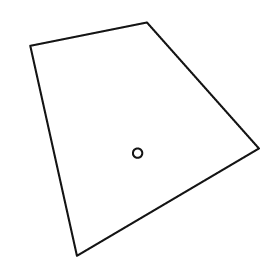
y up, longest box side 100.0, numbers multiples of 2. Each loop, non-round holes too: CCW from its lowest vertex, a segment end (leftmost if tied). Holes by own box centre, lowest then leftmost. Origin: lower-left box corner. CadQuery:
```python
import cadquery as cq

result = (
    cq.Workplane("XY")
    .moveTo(20.0, 0.0)
    .lineTo(98.0, 46.0)
    .lineTo(50.0, 100.0)
    .lineTo(0.0, 90.0)
    .close()
    .moveTo(46.0, 44.0)
    .circle(2.0)
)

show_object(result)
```